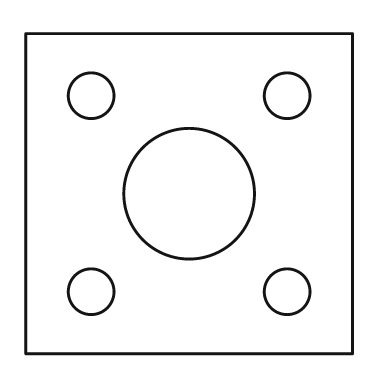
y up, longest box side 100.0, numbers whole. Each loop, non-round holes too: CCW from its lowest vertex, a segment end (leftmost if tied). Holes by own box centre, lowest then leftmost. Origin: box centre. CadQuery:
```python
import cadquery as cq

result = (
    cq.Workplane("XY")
    .moveTo(-50.0, -49.0)
    .lineTo(50.0, -49.0)
    .lineTo(50.0, 49.0)
    .lineTo(-50.0, 49.0)
    .close()
    .moveTo(-30.0, -30.0)
    .circle(7.0)
    .moveTo(30.0, -30.0)
    .circle(7.0)
    .moveTo(0.0, 0.0)
    .circle(20.0)
    .moveTo(-30.0, 30.0)
    .circle(7.0)
    .moveTo(30.0, 30.0)
    .circle(7.0)
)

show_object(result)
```